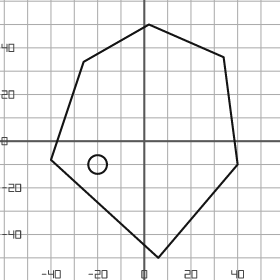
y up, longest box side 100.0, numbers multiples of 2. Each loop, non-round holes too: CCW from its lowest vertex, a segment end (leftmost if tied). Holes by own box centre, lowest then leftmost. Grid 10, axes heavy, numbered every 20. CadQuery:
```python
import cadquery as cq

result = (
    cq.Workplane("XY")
    .moveTo(6.0, -50.0)
    .lineTo(40.0, -10.0)
    .lineTo(34.0, 36.0)
    .lineTo(2.0, 50.0)
    .lineTo(-26.0, 34.0)
    .lineTo(-40.0, -8.0)
    .close()
    .moveTo(-20.0, -10.0)
    .circle(4.0)
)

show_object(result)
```